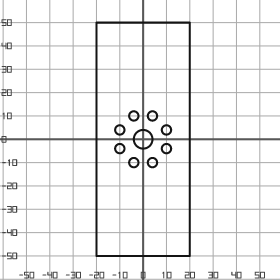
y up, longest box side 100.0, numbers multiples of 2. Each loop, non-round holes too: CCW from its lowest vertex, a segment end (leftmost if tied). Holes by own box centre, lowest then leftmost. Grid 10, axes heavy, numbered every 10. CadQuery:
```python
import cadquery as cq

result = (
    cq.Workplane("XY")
    .moveTo(-20.0, -50.0)
    .lineTo(20.0, -50.0)
    .lineTo(20.0, 50.0)
    .lineTo(-20.0, 50.0)
    .close()
    .moveTo(-4.0, -10.0)
    .circle(2.0)
    .moveTo(4.0, -10.0)
    .circle(2.0)
    .moveTo(-10.0, -4.0)
    .circle(2.0)
    .moveTo(10.0, -4.0)
    .circle(2.0)
    .moveTo(0.0, 0.0)
    .circle(4.0)
    .moveTo(-10.0, 4.0)
    .circle(2.0)
    .moveTo(10.0, 4.0)
    .circle(2.0)
    .moveTo(-4.0, 10.0)
    .circle(2.0)
    .moveTo(4.0, 10.0)
    .circle(2.0)
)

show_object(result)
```